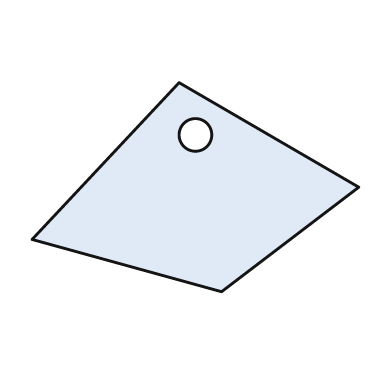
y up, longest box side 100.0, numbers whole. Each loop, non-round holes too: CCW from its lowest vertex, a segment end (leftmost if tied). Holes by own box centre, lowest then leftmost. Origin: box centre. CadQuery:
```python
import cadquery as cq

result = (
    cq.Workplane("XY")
    .moveTo(8.0, -32.0)
    .lineTo(50.0, 0.0)
    .lineTo(-5.0, 32.0)
    .lineTo(-50.0, -16.0)
    .close()
    .moveTo(0.0, 16.0)
    .circle(5.0)
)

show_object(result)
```